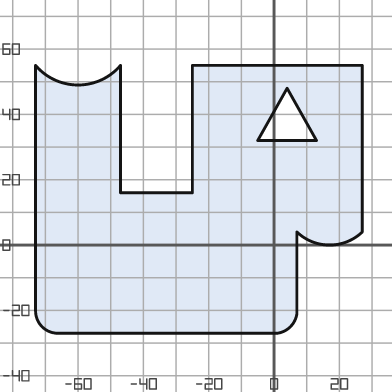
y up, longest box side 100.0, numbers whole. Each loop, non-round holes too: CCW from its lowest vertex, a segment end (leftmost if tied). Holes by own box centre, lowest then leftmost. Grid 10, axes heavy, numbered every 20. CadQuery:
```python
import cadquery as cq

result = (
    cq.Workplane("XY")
    .moveTo(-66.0, -27.0)
    .lineTo(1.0, -27.0)
    .threePointArc((5.0, -25.0), (7.0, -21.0))
    .lineTo(7.0, 4.0)
    .threePointArc((17.0, 0.0), (27.0, 4.0))
    .lineTo(27.0, 55.0)
    .lineTo(-25.0, 55.0)
    .lineTo(-25.0, 16.0)
    .lineTo(-47.0, 16.0)
    .lineTo(-47.0, 55.0)
    .threePointArc((-60.0, 49.0), (-73.0, 55.0))
    .lineTo(-73.0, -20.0)
    .threePointArc((-71.0, -25.0), (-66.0, -27.0))
    .close()
    .moveTo(-5.0, 32.0)
    .lineTo(13.0, 32.0)
    .lineTo(4.0, 48.0)
    .close()
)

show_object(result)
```